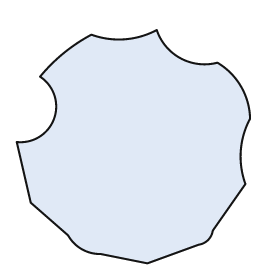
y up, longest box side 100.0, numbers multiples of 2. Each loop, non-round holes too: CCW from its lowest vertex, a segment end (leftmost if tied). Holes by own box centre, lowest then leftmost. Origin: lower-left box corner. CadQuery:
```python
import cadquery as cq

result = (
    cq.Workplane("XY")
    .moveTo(56.0, 0.0)
    .lineTo(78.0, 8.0)
    .threePointArc((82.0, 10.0), (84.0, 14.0))
    .lineTo(98.0, 34.0)
    .threePointArc((96.0, 48.0), (100.0, 62.0))
    .threePointArc((96.0, 76.0), (86.0, 86.0))
    .threePointArc((70.0, 88.0), (60.0, 100.0))
    .threePointArc((46.0, 96.0), (32.0, 98.0))
    .threePointArc((20.0, 90.0), (10.0, 80.0))
    .threePointArc((16.0, 62.0), (0.0, 52.0))
    .lineTo(6.0, 26.0)
    .lineTo(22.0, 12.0)
    .threePointArc((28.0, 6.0), (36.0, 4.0))
    .close()
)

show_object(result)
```